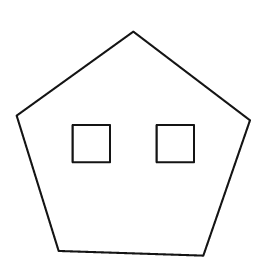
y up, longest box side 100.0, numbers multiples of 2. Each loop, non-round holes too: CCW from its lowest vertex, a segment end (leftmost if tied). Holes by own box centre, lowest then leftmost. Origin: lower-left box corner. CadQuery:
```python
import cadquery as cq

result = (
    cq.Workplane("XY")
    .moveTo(80.0, 0.0)
    .lineTo(100.0, 58.0)
    .lineTo(50.0, 96.0)
    .lineTo(0.0, 60.0)
    .lineTo(18.0, 2.0)
    .close()
    .moveTo(24.0, 40.0)
    .lineTo(40.0, 40.0)
    .lineTo(40.0, 56.0)
    .lineTo(24.0, 56.0)
    .close()
    .moveTo(60.0, 40.0)
    .lineTo(76.0, 40.0)
    .lineTo(76.0, 56.0)
    .lineTo(60.0, 56.0)
    .close()
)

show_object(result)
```